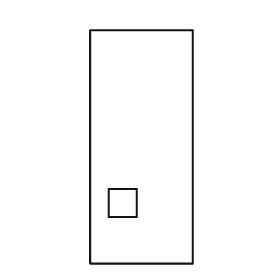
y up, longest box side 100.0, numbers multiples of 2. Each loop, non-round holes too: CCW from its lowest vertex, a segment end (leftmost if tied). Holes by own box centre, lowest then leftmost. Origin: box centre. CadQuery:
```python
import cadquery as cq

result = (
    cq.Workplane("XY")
    .moveTo(-22.0, -50.0)
    .lineTo(22.0, -50.0)
    .lineTo(22.0, 50.0)
    .lineTo(-22.0, 50.0)
    .close()
    .moveTo(-14.0, -30.0)
    .lineTo(-2.0, -30.0)
    .lineTo(-2.0, -18.0)
    .lineTo(-14.0, -18.0)
    .close()
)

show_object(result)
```